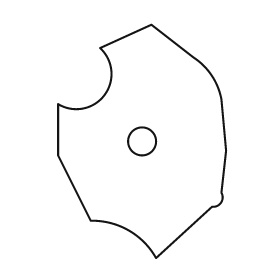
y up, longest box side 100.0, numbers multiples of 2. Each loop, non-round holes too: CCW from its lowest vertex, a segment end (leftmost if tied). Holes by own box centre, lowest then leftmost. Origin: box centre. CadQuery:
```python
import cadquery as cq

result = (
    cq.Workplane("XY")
    .moveTo(6.0, -50.0)
    .lineTo(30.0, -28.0)
    .threePointArc((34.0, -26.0), (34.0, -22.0))
    .lineTo(36.0, -4.0)
    .lineTo(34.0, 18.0)
    .threePointArc((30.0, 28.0), (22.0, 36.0))
    .lineTo(4.0, 50.0)
    .lineTo(-18.0, 40.0)
    .threePointArc((-16.0, 20.0), (-36.0, 16.0))
    .lineTo(-36.0, -6.0)
    .lineTo(-22.0, -34.0)
    .threePointArc((-6.0, -38.0), (6.0, -50.0))
    .close()
    .moveTo(0.0, 0.0)
    .circle(6.0)
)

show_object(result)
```